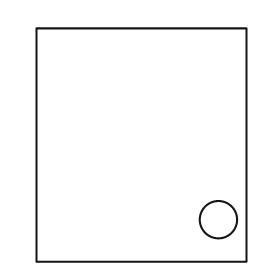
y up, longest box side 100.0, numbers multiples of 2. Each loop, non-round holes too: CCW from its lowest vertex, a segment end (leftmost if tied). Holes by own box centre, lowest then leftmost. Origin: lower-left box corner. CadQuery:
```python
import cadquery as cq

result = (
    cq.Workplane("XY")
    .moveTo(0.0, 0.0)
    .lineTo(90.0, 0.0)
    .lineTo(90.0, 100.0)
    .lineTo(0.0, 100.0)
    .close()
    .moveTo(78.0, 18.0)
    .circle(8.0)
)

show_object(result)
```